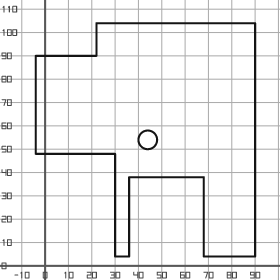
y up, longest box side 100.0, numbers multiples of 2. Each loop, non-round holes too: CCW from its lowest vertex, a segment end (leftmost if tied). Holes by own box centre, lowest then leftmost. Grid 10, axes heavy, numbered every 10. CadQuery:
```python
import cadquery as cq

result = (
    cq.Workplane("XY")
    .moveTo(30.0, 4.0)
    .lineTo(36.0, 4.0)
    .lineTo(36.0, 38.0)
    .lineTo(68.0, 38.0)
    .lineTo(68.0, 4.0)
    .lineTo(90.0, 4.0)
    .lineTo(90.0, 104.0)
    .lineTo(22.0, 104.0)
    .lineTo(22.0, 90.0)
    .lineTo(-4.0, 90.0)
    .lineTo(-4.0, 48.0)
    .lineTo(30.0, 48.0)
    .close()
    .moveTo(44.0, 54.0)
    .circle(4.0)
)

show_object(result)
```